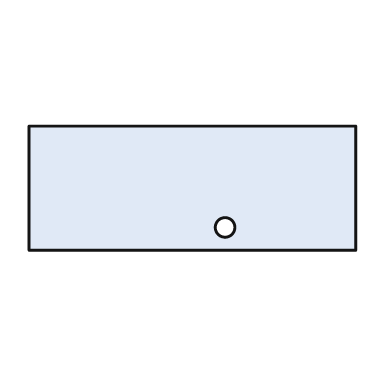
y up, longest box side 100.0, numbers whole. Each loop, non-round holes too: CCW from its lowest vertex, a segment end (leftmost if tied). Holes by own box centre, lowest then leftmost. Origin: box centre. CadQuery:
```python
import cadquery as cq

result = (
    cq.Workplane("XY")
    .moveTo(-50.0, -19.0)
    .lineTo(50.0, -19.0)
    .lineTo(50.0, 19.0)
    .lineTo(-50.0, 19.0)
    .close()
    .moveTo(10.0, -12.0)
    .circle(3.0)
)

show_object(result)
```